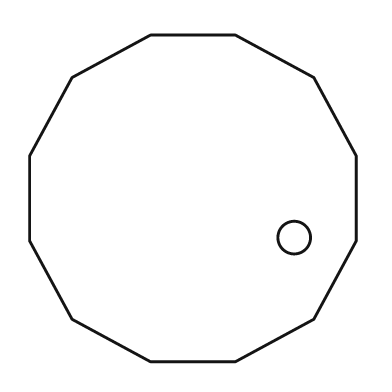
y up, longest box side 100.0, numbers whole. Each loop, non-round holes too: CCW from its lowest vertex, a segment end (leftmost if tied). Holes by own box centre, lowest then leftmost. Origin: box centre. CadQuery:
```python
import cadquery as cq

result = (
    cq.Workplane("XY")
    .moveTo(-13.0, -50.0)
    .lineTo(13.0, -50.0)
    .lineTo(37.0, -37.0)
    .lineTo(50.0, -13.0)
    .lineTo(50.0, 13.0)
    .lineTo(37.0, 37.0)
    .lineTo(13.0, 50.0)
    .lineTo(-13.0, 50.0)
    .lineTo(-37.0, 37.0)
    .lineTo(-50.0, 13.0)
    .lineTo(-50.0, -13.0)
    .lineTo(-37.0, -37.0)
    .close()
    .moveTo(31.0, -12.0)
    .circle(5.0)
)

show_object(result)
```